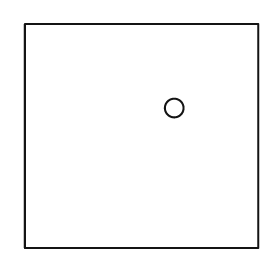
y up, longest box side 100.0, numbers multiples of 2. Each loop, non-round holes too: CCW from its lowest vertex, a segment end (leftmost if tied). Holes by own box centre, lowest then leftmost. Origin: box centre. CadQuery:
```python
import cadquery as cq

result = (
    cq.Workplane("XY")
    .moveTo(-50.0, -48.0)
    .lineTo(50.0, -48.0)
    .lineTo(50.0, 48.0)
    .lineTo(-50.0, 48.0)
    .close()
    .moveTo(14.0, 12.0)
    .circle(4.0)
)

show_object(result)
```